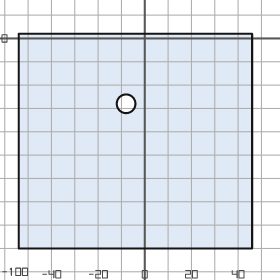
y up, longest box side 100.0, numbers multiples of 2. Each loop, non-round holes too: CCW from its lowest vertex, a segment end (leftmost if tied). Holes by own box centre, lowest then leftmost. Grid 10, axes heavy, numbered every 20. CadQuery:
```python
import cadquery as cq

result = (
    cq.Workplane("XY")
    .moveTo(-54.0, -90.0)
    .lineTo(46.0, -90.0)
    .lineTo(46.0, 2.0)
    .lineTo(-54.0, 2.0)
    .close()
    .moveTo(-8.0, -28.0)
    .circle(4.0)
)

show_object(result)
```